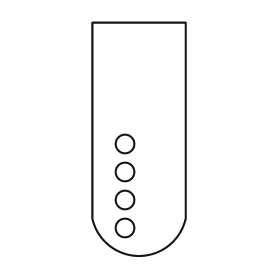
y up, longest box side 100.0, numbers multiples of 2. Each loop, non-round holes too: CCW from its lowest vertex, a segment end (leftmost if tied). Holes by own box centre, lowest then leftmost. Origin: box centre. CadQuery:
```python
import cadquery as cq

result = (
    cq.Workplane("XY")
    .moveTo(-20.0, -34.0)
    .threePointArc((0.0, -50.0), (20.0, -34.0))
    .lineTo(20.0, 50.0)
    .lineTo(-20.0, 50.0)
    .close()
    .moveTo(-6.0, -38.0)
    .circle(4.0)
    .moveTo(-6.0, -26.0)
    .circle(4.0)
    .moveTo(-6.0, -14.0)
    .circle(4.0)
    .moveTo(-6.0, -2.0)
    .circle(4.0)
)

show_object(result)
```